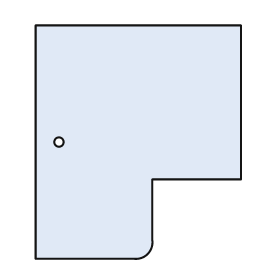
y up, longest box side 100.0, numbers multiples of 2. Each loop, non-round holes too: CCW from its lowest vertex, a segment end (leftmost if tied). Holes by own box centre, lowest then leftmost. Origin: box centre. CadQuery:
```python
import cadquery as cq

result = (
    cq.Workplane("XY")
    .moveTo(-44.0, -50.0)
    .lineTo(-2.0, -50.0)
    .threePointArc((4.0, -48.0), (6.0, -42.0))
    .lineTo(6.0, -16.0)
    .lineTo(44.0, -16.0)
    .lineTo(44.0, 50.0)
    .lineTo(-44.0, 50.0)
    .close()
    .moveTo(-34.0, 0.0)
    .circle(2.0)
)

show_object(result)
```